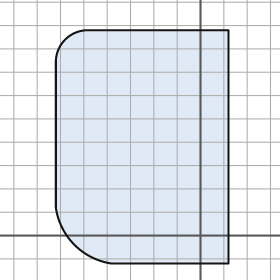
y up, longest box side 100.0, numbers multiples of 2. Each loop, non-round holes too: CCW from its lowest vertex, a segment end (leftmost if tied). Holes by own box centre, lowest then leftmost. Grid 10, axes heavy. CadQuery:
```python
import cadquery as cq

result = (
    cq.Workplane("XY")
    .moveTo(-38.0, -12.0)
    .lineTo(12.0, -12.0)
    .lineTo(12.0, 88.0)
    .lineTo(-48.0, 88.0)
    .threePointArc((-58.0, 84.0), (-62.0, 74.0))
    .lineTo(-62.0, 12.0)
    .threePointArc((-54.0, -4.0), (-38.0, -12.0))
    .close()
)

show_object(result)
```